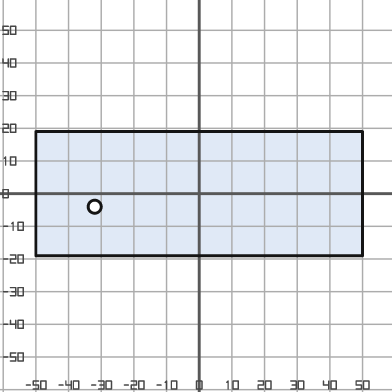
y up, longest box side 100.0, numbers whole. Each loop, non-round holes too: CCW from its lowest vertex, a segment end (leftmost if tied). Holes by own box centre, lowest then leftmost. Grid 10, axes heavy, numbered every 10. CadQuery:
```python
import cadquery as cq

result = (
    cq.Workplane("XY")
    .moveTo(-50.0, -19.0)
    .lineTo(50.0, -19.0)
    .lineTo(50.0, 19.0)
    .lineTo(-50.0, 19.0)
    .close()
    .moveTo(-32.0, -4.0)
    .circle(2.0)
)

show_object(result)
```